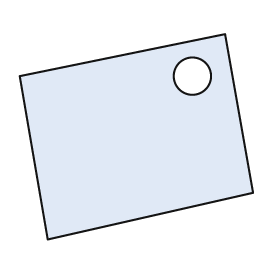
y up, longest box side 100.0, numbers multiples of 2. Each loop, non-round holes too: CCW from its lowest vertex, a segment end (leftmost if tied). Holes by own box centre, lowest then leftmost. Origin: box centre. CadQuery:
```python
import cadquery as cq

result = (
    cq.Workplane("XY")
    .moveTo(-38.0, -44.0)
    .lineTo(50.0, -24.0)
    .lineTo(38.0, 44.0)
    .lineTo(-50.0, 26.0)
    .close()
    .moveTo(24.0, 26.0)
    .circle(8.0)
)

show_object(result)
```